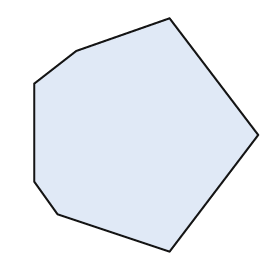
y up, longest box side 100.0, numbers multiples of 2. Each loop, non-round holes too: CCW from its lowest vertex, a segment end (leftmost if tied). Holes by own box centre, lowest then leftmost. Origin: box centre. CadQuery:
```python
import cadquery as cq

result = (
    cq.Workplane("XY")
    .moveTo(10.0, -50.0)
    .lineTo(48.0, 0.0)
    .lineTo(10.0, 50.0)
    .lineTo(-30.0, 36.0)
    .lineTo(-48.0, 22.0)
    .lineTo(-48.0, -20.0)
    .lineTo(-38.0, -34.0)
    .close()
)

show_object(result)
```